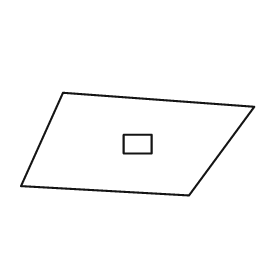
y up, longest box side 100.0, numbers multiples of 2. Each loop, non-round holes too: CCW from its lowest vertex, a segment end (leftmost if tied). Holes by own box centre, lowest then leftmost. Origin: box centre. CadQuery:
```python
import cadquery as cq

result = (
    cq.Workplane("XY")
    .moveTo(22.0, -22.0)
    .lineTo(50.0, 16.0)
    .lineTo(-32.0, 22.0)
    .lineTo(-50.0, -18.0)
    .close()
    .moveTo(-6.0, -4.0)
    .lineTo(6.0, -4.0)
    .lineTo(6.0, 4.0)
    .lineTo(-6.0, 4.0)
    .close()
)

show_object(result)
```